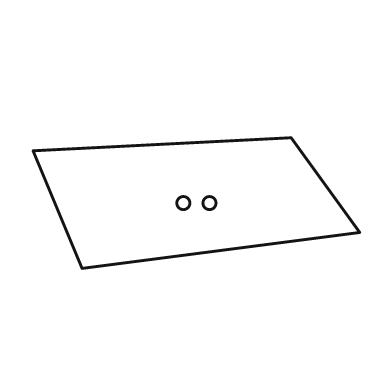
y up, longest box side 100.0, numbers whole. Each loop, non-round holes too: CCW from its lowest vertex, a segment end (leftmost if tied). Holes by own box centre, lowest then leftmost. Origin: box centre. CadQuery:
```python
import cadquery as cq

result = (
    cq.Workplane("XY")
    .moveTo(-35.0, -20.0)
    .lineTo(50.0, -9.0)
    .lineTo(29.0, 20.0)
    .lineTo(-50.0, 16.0)
    .close()
    .moveTo(-4.0, 0.0)
    .circle(2.0)
    .moveTo(4.0, 0.0)
    .circle(2.0)
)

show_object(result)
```